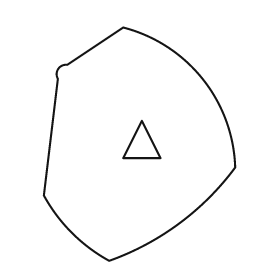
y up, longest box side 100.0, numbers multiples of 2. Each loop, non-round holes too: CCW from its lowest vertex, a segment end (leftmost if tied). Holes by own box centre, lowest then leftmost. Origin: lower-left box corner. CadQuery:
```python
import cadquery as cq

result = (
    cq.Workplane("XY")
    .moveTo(28.0, 0.0)
    .threePointArc((58.0, 16.0), (82.0, 40.0))
    .threePointArc((68.0, 78.0), (34.0, 100.0))
    .lineTo(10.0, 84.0)
    .threePointArc((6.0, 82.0), (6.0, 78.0))
    .lineTo(0.0, 28.0)
    .threePointArc((12.0, 12.0), (28.0, 0.0))
    .close()
    .moveTo(34.0, 44.0)
    .lineTo(50.0, 44.0)
    .lineTo(42.0, 60.0)
    .close()
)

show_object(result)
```